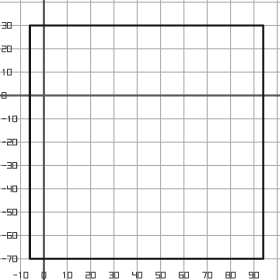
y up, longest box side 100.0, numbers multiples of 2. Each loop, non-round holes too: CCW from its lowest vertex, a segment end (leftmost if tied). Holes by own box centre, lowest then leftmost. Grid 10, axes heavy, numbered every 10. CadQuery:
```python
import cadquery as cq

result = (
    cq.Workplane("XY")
    .moveTo(-6.0, -70.0)
    .lineTo(94.0, -70.0)
    .lineTo(94.0, 30.0)
    .lineTo(-6.0, 30.0)
    .close()
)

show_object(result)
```